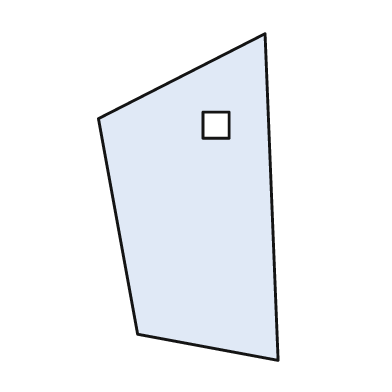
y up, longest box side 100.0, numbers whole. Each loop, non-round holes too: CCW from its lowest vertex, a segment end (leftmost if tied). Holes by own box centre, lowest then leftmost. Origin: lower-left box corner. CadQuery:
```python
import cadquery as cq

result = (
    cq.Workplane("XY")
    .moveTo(55.0, 0.0)
    .lineTo(51.0, 100.0)
    .lineTo(0.0, 74.0)
    .lineTo(12.0, 8.0)
    .close()
    .moveTo(32.0, 68.0)
    .lineTo(40.0, 68.0)
    .lineTo(40.0, 76.0)
    .lineTo(32.0, 76.0)
    .close()
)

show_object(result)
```